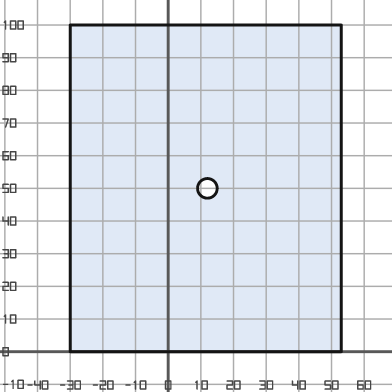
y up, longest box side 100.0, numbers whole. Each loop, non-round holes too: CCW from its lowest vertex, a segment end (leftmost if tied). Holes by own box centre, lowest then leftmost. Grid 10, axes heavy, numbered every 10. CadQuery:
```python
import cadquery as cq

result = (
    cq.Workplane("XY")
    .moveTo(-30.0, 0.0)
    .lineTo(53.0, 0.0)
    .lineTo(53.0, 100.0)
    .lineTo(-30.0, 100.0)
    .close()
    .moveTo(12.0, 50.0)
    .circle(3.0)
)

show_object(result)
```